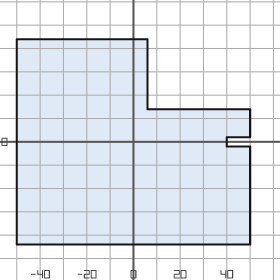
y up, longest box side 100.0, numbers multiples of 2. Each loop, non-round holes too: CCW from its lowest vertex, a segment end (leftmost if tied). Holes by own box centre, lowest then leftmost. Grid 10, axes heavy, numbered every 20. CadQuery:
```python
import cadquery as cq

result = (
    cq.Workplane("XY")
    .moveTo(-50.0, -44.0)
    .lineTo(50.0, -44.0)
    .lineTo(50.0, -2.0)
    .lineTo(40.0, -2.0)
    .lineTo(40.0, 2.0)
    .lineTo(50.0, 2.0)
    .lineTo(50.0, 14.0)
    .lineTo(6.0, 14.0)
    .lineTo(6.0, 44.0)
    .lineTo(-50.0, 44.0)
    .close()
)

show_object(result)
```